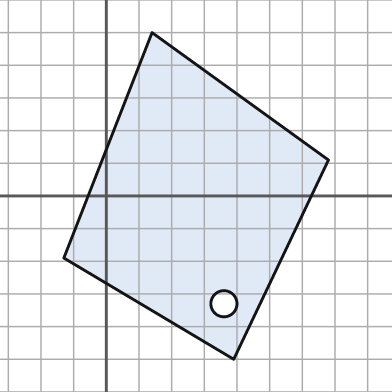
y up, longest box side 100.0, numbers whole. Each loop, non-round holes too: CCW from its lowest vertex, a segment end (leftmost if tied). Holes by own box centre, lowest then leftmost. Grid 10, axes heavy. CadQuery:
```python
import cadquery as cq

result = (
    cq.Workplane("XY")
    .moveTo(39.0, -50.0)
    .lineTo(68.0, 11.0)
    .lineTo(14.0, 50.0)
    .lineTo(-13.0, -19.0)
    .close()
    .moveTo(36.0, -33.0)
    .circle(4.0)
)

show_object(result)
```